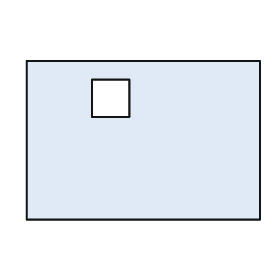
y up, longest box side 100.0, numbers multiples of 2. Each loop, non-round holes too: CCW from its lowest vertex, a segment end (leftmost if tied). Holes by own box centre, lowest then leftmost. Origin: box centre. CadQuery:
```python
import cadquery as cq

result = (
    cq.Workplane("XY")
    .moveTo(-50.0, -34.0)
    .lineTo(50.0, -34.0)
    .lineTo(50.0, 34.0)
    .lineTo(-50.0, 34.0)
    .close()
    .moveTo(-22.0, 10.0)
    .lineTo(-6.0, 10.0)
    .lineTo(-6.0, 26.0)
    .lineTo(-22.0, 26.0)
    .close()
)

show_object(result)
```